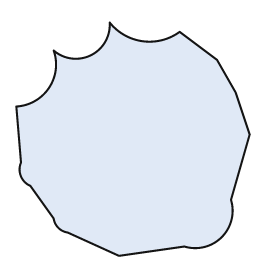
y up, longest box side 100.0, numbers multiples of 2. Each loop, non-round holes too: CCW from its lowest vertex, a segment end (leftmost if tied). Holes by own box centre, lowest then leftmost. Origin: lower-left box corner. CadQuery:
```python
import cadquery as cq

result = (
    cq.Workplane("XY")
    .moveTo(44.0, 0.0)
    .lineTo(72.0, 4.0)
    .threePointArc((88.0, 8.0), (92.0, 24.0))
    .lineTo(100.0, 52.0)
    .lineTo(94.0, 70.0)
    .lineTo(86.0, 84.0)
    .lineTo(70.0, 96.0)
    .threePointArc((54.0, 92.0), (40.0, 100.0))
    .threePointArc((32.0, 86.0), (16.0, 88.0))
    .threePointArc((14.0, 72.0), (0.0, 64.0))
    .lineTo(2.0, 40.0)
    .threePointArc((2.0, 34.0), (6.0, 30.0))
    .lineTo(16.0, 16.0)
    .threePointArc((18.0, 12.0), (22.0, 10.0))
    .close()
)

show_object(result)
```